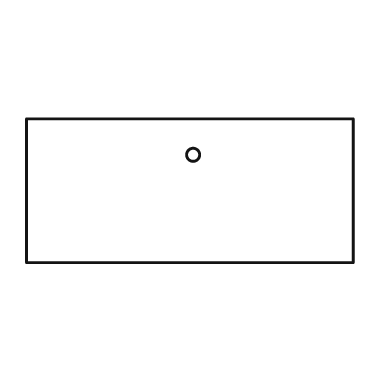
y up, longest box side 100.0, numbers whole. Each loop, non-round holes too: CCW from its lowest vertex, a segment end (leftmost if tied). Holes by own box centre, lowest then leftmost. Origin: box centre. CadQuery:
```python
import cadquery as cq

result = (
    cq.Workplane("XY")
    .moveTo(-50.0, -22.0)
    .lineTo(50.0, -22.0)
    .lineTo(50.0, 22.0)
    .lineTo(-50.0, 22.0)
    .close()
    .moveTo(1.0, 11.0)
    .circle(2.0)
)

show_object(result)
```